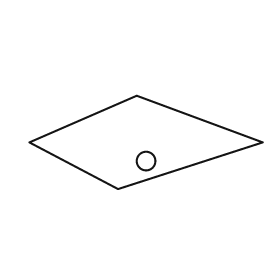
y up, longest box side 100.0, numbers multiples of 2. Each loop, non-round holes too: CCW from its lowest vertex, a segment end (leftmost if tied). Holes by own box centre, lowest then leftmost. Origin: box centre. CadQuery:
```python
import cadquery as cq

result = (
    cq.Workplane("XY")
    .moveTo(-12.0, -20.0)
    .lineTo(50.0, 0.0)
    .lineTo(-4.0, 20.0)
    .lineTo(-50.0, 0.0)
    .close()
    .moveTo(0.0, -8.0)
    .circle(4.0)
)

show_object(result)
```